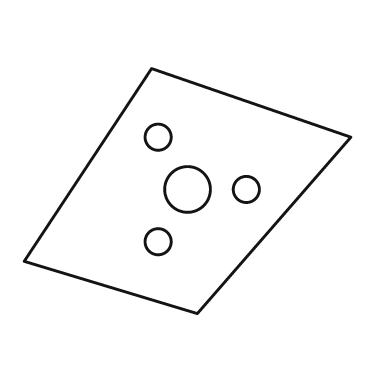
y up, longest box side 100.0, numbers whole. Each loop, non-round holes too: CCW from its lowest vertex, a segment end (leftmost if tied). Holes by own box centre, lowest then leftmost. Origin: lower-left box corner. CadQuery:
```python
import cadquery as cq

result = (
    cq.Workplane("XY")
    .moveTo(53.0, 0.0)
    .lineTo(100.0, 54.0)
    .lineTo(39.0, 75.0)
    .lineTo(0.0, 16.0)
    .close()
    .moveTo(41.0, 22.0)
    .circle(4.0)
    .moveTo(50.0, 38.0)
    .circle(7.0)
    .moveTo(68.0, 38.0)
    .circle(4.0)
    .moveTo(41.0, 54.0)
    .circle(4.0)
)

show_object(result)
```